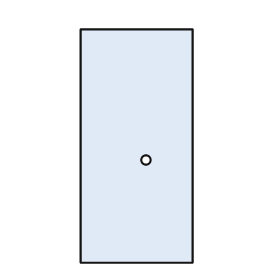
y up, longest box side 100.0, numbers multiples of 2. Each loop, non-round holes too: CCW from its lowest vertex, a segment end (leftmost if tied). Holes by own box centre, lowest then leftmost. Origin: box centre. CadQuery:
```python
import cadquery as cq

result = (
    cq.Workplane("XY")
    .moveTo(-24.0, -50.0)
    .lineTo(24.0, -50.0)
    .lineTo(24.0, 50.0)
    .lineTo(-24.0, 50.0)
    .close()
    .moveTo(4.0, -6.0)
    .circle(2.0)
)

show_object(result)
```